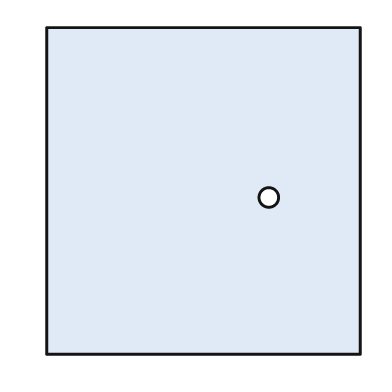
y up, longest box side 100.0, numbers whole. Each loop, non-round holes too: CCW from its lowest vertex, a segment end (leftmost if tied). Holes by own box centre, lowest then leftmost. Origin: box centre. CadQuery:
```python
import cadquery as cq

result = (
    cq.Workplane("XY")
    .moveTo(-48.0, -50.0)
    .lineTo(48.0, -50.0)
    .lineTo(48.0, 50.0)
    .lineTo(-48.0, 50.0)
    .close()
    .moveTo(20.0, -2.0)
    .circle(3.0)
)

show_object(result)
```